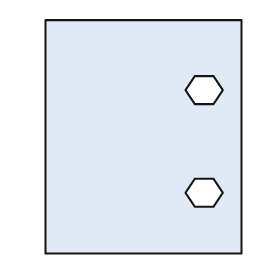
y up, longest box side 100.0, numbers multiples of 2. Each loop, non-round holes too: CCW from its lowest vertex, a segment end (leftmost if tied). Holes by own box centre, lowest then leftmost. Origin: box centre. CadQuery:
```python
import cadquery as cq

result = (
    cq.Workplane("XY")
    .moveTo(-42.0, -50.0)
    .lineTo(42.0, -50.0)
    .lineTo(42.0, 50.0)
    .lineTo(-42.0, 50.0)
    .close()
    .moveTo(22.0, -30.0)
    .lineTo(30.0, -30.0)
    .lineTo(34.0, -24.0)
    .lineTo(30.0, -18.0)
    .lineTo(22.0, -18.0)
    .lineTo(18.0, -24.0)
    .close()
    .moveTo(22.0, 14.0)
    .lineTo(30.0, 14.0)
    .lineTo(34.0, 20.0)
    .lineTo(30.0, 26.0)
    .lineTo(22.0, 26.0)
    .lineTo(18.0, 20.0)
    .close()
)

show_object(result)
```